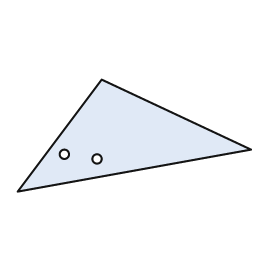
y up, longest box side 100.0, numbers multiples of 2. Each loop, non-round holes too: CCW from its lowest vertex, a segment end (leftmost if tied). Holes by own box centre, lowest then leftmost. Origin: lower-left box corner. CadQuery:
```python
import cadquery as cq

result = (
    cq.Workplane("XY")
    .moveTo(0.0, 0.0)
    .lineTo(100.0, 18.0)
    .lineTo(36.0, 48.0)
    .close()
    .moveTo(34.0, 14.0)
    .circle(2.0)
    .moveTo(20.0, 16.0)
    .circle(2.0)
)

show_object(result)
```